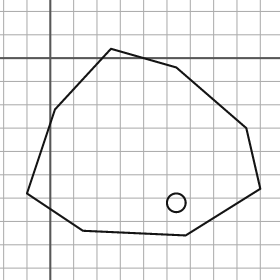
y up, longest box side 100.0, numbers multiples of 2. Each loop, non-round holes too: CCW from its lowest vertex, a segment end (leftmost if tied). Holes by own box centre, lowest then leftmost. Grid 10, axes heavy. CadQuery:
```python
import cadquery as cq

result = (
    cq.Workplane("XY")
    .moveTo(58.0, -76.0)
    .lineTo(90.0, -56.0)
    .lineTo(84.0, -30.0)
    .lineTo(54.0, -4.0)
    .lineTo(26.0, 4.0)
    .lineTo(2.0, -22.0)
    .lineTo(-10.0, -58.0)
    .lineTo(14.0, -74.0)
    .close()
    .moveTo(54.0, -62.0)
    .circle(4.0)
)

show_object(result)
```